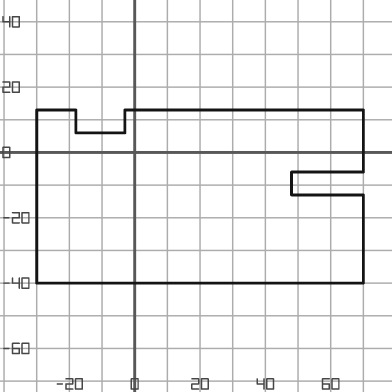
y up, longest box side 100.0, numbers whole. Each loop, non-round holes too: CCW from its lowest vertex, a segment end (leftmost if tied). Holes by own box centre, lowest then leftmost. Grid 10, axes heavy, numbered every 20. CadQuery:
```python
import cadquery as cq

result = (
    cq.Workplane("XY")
    .moveTo(-30.0, -40.0)
    .lineTo(70.0, -40.0)
    .lineTo(70.0, -13.0)
    .lineTo(48.0, -13.0)
    .lineTo(48.0, -6.0)
    .lineTo(70.0, -6.0)
    .lineTo(70.0, 13.0)
    .lineTo(-3.0, 13.0)
    .lineTo(-3.0, 6.0)
    .lineTo(-18.0, 6.0)
    .lineTo(-18.0, 13.0)
    .lineTo(-30.0, 13.0)
    .close()
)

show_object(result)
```